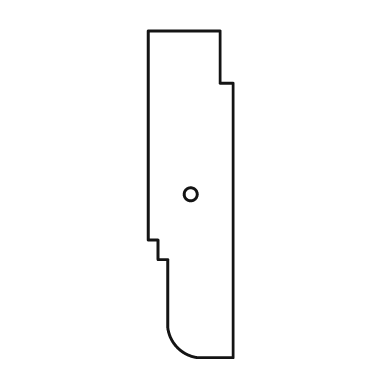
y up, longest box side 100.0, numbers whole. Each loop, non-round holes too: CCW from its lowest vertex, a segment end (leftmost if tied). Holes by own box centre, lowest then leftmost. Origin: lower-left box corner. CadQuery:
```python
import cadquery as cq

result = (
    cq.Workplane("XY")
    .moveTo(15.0, 0.0)
    .lineTo(26.0, 0.0)
    .lineTo(26.0, 84.0)
    .lineTo(22.0, 84.0)
    .lineTo(22.0, 100.0)
    .lineTo(0.0, 100.0)
    .lineTo(0.0, 36.0)
    .lineTo(3.0, 36.0)
    .lineTo(3.0, 30.0)
    .lineTo(6.0, 30.0)
    .lineTo(6.0, 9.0)
    .threePointArc((9.0, 3.0), (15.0, 0.0))
    .close()
    .moveTo(13.0, 50.0)
    .circle(2.0)
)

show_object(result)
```